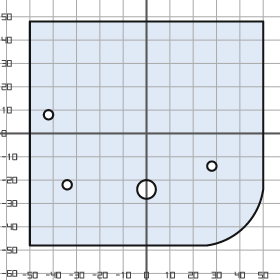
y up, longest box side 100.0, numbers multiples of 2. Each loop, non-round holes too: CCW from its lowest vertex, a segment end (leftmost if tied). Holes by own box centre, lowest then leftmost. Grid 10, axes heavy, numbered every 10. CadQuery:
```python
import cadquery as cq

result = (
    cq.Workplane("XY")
    .moveTo(-50.0, -48.0)
    .lineTo(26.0, -48.0)
    .threePointArc((42.0, -40.0), (50.0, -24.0))
    .lineTo(50.0, 48.0)
    .lineTo(-50.0, 48.0)
    .close()
    .moveTo(0.0, -24.0)
    .circle(4.0)
    .moveTo(-34.0, -22.0)
    .circle(2.0)
    .moveTo(28.0, -14.0)
    .circle(2.0)
    .moveTo(-42.0, 8.0)
    .circle(2.0)
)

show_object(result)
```